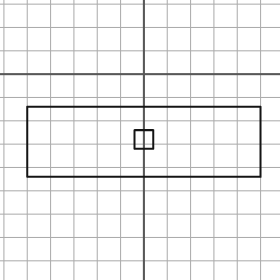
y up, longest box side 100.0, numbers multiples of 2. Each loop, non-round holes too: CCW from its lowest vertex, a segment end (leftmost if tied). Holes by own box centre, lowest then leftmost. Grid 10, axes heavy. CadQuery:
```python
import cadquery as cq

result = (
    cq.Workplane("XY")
    .moveTo(-50.0, -44.0)
    .lineTo(50.0, -44.0)
    .lineTo(50.0, -14.0)
    .lineTo(-50.0, -14.0)
    .close()
    .moveTo(-4.0, -32.0)
    .lineTo(4.0, -32.0)
    .lineTo(4.0, -24.0)
    .lineTo(-4.0, -24.0)
    .close()
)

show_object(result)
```